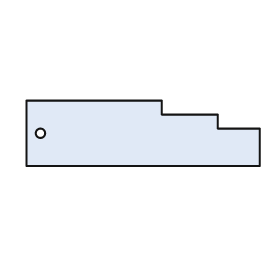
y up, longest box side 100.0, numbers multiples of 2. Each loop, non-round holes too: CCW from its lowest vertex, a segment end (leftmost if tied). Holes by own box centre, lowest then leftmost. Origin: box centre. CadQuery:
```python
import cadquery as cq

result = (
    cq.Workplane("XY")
    .moveTo(-50.0, -14.0)
    .lineTo(50.0, -14.0)
    .lineTo(50.0, 2.0)
    .lineTo(32.0, 2.0)
    .lineTo(32.0, 8.0)
    .lineTo(8.0, 8.0)
    .lineTo(8.0, 14.0)
    .lineTo(-50.0, 14.0)
    .close()
    .moveTo(-44.0, 0.0)
    .circle(2.0)
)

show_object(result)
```